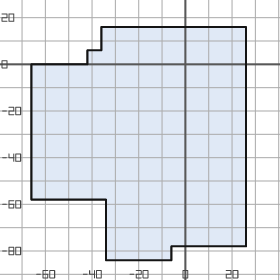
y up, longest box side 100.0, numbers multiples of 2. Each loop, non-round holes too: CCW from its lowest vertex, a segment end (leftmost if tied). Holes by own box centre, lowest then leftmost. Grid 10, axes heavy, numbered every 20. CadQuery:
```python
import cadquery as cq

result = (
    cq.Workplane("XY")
    .moveTo(-34.0, -84.0)
    .lineTo(-6.0, -84.0)
    .lineTo(-6.0, -78.0)
    .lineTo(26.0, -78.0)
    .lineTo(26.0, 16.0)
    .lineTo(-36.0, 16.0)
    .lineTo(-36.0, 6.0)
    .lineTo(-42.0, 6.0)
    .lineTo(-42.0, 0.0)
    .lineTo(-66.0, 0.0)
    .lineTo(-66.0, -58.0)
    .lineTo(-34.0, -58.0)
    .close()
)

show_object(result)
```